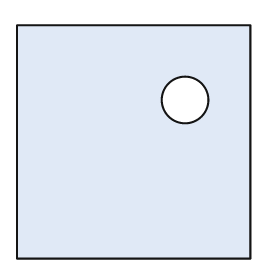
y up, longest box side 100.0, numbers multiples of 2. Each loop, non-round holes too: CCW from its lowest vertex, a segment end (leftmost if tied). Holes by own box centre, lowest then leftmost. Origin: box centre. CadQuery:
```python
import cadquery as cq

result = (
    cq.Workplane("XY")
    .moveTo(-50.0, -50.0)
    .lineTo(50.0, -50.0)
    .lineTo(50.0, 50.0)
    .lineTo(-50.0, 50.0)
    .close()
    .moveTo(22.0, 18.0)
    .circle(10.0)
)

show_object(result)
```